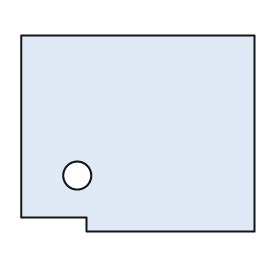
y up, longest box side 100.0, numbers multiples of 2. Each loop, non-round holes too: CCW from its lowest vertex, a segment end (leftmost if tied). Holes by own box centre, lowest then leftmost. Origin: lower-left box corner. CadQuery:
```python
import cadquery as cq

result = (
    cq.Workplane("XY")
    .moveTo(28.0, 0.0)
    .lineTo(100.0, 0.0)
    .lineTo(100.0, 84.0)
    .lineTo(0.0, 84.0)
    .lineTo(0.0, 6.0)
    .lineTo(28.0, 6.0)
    .close()
    .moveTo(24.0, 24.0)
    .circle(6.0)
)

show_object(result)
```